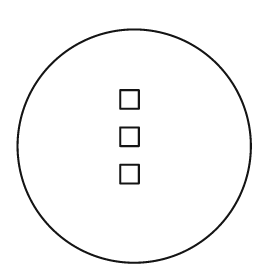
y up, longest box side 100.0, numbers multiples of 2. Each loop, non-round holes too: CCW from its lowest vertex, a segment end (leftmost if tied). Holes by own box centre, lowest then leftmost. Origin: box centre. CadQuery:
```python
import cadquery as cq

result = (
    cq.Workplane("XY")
    .moveTo(0.0, 0.0)
    .circle(50.0)
    .moveTo(-6.0, -16.0)
    .lineTo(2.0, -16.0)
    .lineTo(2.0, -8.0)
    .lineTo(-6.0, -8.0)
    .close()
    .moveTo(-6.0, 0.0)
    .lineTo(2.0, 0.0)
    .lineTo(2.0, 8.0)
    .lineTo(-6.0, 8.0)
    .close()
    .moveTo(-6.0, 16.0)
    .lineTo(2.0, 16.0)
    .lineTo(2.0, 24.0)
    .lineTo(-6.0, 24.0)
    .close()
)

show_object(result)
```